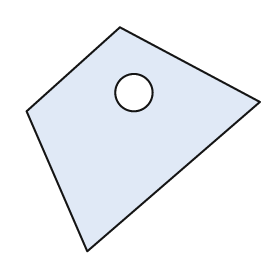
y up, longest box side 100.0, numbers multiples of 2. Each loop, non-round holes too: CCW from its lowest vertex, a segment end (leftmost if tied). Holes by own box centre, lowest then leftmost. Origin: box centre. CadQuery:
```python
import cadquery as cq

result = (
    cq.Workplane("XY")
    .moveTo(-24.0, -48.0)
    .lineTo(50.0, 16.0)
    .lineTo(-10.0, 48.0)
    .lineTo(-50.0, 12.0)
    .close()
    .moveTo(-4.0, 20.0)
    .circle(8.0)
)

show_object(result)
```